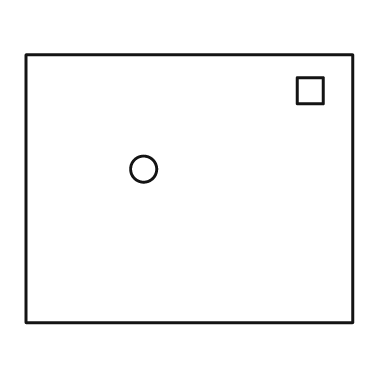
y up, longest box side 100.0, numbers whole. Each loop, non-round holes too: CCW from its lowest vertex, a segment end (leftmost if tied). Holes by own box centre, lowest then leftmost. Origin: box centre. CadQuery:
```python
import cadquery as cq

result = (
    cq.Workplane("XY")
    .moveTo(-50.0, -41.0)
    .lineTo(50.0, -41.0)
    .lineTo(50.0, 41.0)
    .lineTo(-50.0, 41.0)
    .close()
    .moveTo(-14.0, 6.0)
    .circle(4.0)
    .moveTo(33.0, 26.0)
    .lineTo(41.0, 26.0)
    .lineTo(41.0, 34.0)
    .lineTo(33.0, 34.0)
    .close()
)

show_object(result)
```